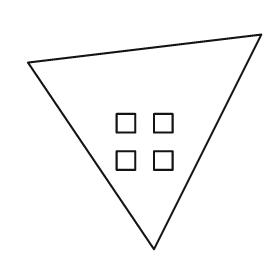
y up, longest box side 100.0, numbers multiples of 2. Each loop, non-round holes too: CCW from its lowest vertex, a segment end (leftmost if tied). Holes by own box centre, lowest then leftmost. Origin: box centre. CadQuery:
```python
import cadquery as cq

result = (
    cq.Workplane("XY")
    .moveTo(4.0, -46.0)
    .lineTo(50.0, 46.0)
    .lineTo(-50.0, 34.0)
    .close()
    .moveTo(-12.0, -12.0)
    .lineTo(-4.0, -12.0)
    .lineTo(-4.0, -4.0)
    .lineTo(-12.0, -4.0)
    .close()
    .moveTo(4.0, -12.0)
    .lineTo(12.0, -12.0)
    .lineTo(12.0, -4.0)
    .lineTo(4.0, -4.0)
    .close()
    .moveTo(-12.0, 4.0)
    .lineTo(-4.0, 4.0)
    .lineTo(-4.0, 12.0)
    .lineTo(-12.0, 12.0)
    .close()
    .moveTo(4.0, 4.0)
    .lineTo(12.0, 4.0)
    .lineTo(12.0, 12.0)
    .lineTo(4.0, 12.0)
    .close()
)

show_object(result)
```